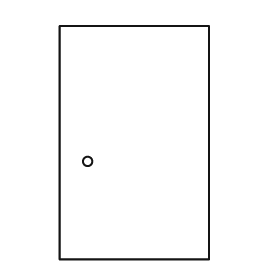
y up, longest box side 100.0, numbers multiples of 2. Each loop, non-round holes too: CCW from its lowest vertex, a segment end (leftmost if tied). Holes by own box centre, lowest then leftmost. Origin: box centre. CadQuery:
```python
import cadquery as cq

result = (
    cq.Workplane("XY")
    .moveTo(-32.0, -50.0)
    .lineTo(32.0, -50.0)
    .lineTo(32.0, 50.0)
    .lineTo(-32.0, 50.0)
    .close()
    .moveTo(-20.0, -8.0)
    .circle(2.0)
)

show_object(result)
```